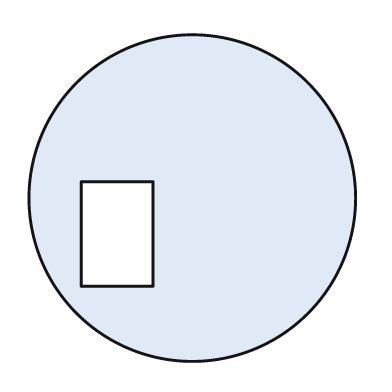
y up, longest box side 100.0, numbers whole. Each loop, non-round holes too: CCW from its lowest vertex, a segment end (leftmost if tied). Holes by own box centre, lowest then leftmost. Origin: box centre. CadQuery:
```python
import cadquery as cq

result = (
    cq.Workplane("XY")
    .moveTo(0.0, 0.0)
    .circle(50.0)
    .moveTo(-34.0, -27.0)
    .lineTo(-12.0, -27.0)
    .lineTo(-12.0, 5.0)
    .lineTo(-34.0, 5.0)
    .close()
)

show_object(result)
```